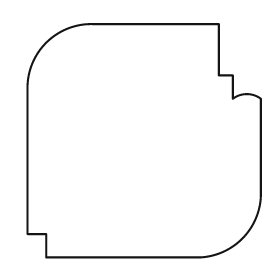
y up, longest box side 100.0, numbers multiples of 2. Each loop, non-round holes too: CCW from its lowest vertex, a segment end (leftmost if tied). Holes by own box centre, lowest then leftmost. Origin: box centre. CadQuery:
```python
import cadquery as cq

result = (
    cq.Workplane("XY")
    .moveTo(-42.0, -50.0)
    .lineTo(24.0, -50.0)
    .threePointArc((42.0, -42.0), (50.0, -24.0))
    .lineTo(50.0, 18.0)
    .threePointArc((44.0, 20.0), (38.0, 18.0))
    .lineTo(38.0, 28.0)
    .lineTo(32.0, 28.0)
    .lineTo(32.0, 50.0)
    .lineTo(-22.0, 50.0)
    .threePointArc((-42.0, 42.0), (-50.0, 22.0))
    .lineTo(-50.0, -40.0)
    .lineTo(-42.0, -40.0)
    .close()
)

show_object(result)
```